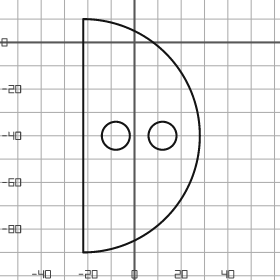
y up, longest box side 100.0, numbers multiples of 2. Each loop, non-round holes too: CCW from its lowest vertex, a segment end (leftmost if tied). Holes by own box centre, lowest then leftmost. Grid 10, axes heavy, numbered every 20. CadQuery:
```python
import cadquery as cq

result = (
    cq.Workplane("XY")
    .moveTo(-22.0, -90.0)
    .threePointArc((28.0, -40.0), (-22.0, 10.0))
    .close()
    .moveTo(-8.0, -40.0)
    .circle(6.0)
    .moveTo(12.0, -40.0)
    .circle(6.0)
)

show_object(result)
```